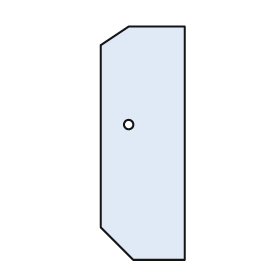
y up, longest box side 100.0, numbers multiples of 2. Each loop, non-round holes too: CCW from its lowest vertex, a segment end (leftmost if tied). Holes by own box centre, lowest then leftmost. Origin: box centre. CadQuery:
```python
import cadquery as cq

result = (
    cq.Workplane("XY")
    .moveTo(-4.0, -50.0)
    .lineTo(18.0, -50.0)
    .lineTo(18.0, 50.0)
    .lineTo(-6.0, 50.0)
    .lineTo(-18.0, 42.0)
    .lineTo(-18.0, -36.0)
    .close()
    .moveTo(-6.0, 8.0)
    .circle(2.0)
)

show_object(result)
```